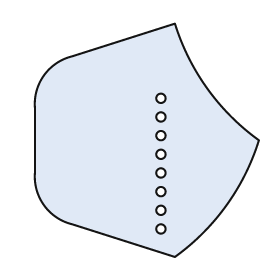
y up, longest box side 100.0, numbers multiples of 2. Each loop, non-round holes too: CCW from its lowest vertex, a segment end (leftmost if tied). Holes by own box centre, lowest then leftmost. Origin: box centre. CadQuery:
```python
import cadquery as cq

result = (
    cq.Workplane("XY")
    .moveTo(12.0, -50.0)
    .threePointArc((34.0, -28.0), (48.0, 0.0))
    .threePointArc((26.0, 22.0), (12.0, 50.0))
    .lineTo(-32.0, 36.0)
    .threePointArc((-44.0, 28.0), (-48.0, 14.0))
    .lineTo(-48.0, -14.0)
    .threePointArc((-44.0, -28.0), (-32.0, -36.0))
    .close()
    .moveTo(6.0, -38.0)
    .circle(2.0)
    .moveTo(6.0, -30.0)
    .circle(2.0)
    .moveTo(6.0, -22.0)
    .circle(2.0)
    .moveTo(6.0, -14.0)
    .circle(2.0)
    .moveTo(6.0, -6.0)
    .circle(2.0)
    .moveTo(6.0, 2.0)
    .circle(2.0)
    .moveTo(6.0, 10.0)
    .circle(2.0)
    .moveTo(6.0, 18.0)
    .circle(2.0)
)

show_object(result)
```